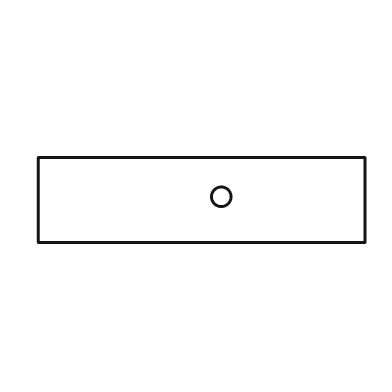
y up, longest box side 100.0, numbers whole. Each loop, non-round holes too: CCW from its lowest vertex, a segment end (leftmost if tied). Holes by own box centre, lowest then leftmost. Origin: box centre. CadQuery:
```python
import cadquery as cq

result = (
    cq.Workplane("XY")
    .moveTo(-50.0, -13.0)
    .lineTo(50.0, -13.0)
    .lineTo(50.0, 13.0)
    .lineTo(-50.0, 13.0)
    .close()
    .moveTo(6.0, 1.0)
    .circle(3.0)
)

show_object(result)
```